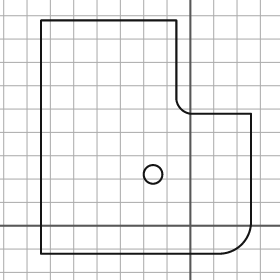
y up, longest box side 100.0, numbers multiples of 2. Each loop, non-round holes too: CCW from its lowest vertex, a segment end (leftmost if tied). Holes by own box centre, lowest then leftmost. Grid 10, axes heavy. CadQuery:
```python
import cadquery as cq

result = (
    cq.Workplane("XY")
    .moveTo(-64.0, -12.0)
    .lineTo(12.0, -12.0)
    .threePointArc((22.0, -8.0), (26.0, 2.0))
    .lineTo(26.0, 48.0)
    .lineTo(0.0, 48.0)
    .threePointArc((-4.0, 50.0), (-6.0, 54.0))
    .lineTo(-6.0, 88.0)
    .lineTo(-64.0, 88.0)
    .close()
    .moveTo(-16.0, 22.0)
    .circle(4.0)
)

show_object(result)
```